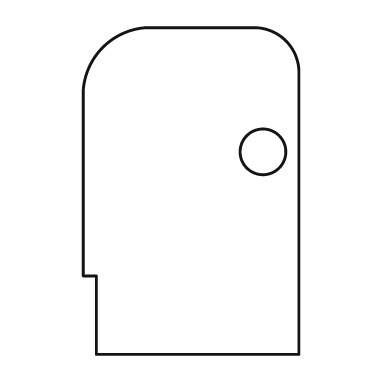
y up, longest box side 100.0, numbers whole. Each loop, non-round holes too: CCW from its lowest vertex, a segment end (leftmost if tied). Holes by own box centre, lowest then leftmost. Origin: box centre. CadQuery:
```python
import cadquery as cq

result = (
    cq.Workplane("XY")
    .moveTo(-29.0, -50.0)
    .lineTo(33.0, -50.0)
    .lineTo(33.0, 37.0)
    .threePointArc((29.0, 46.0), (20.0, 50.0))
    .lineTo(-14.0, 50.0)
    .threePointArc((-27.0, 44.0), (-33.0, 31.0))
    .lineTo(-33.0, -26.0)
    .lineTo(-29.0, -26.0)
    .close()
    .moveTo(22.0, 12.0)
    .circle(7.0)
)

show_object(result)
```